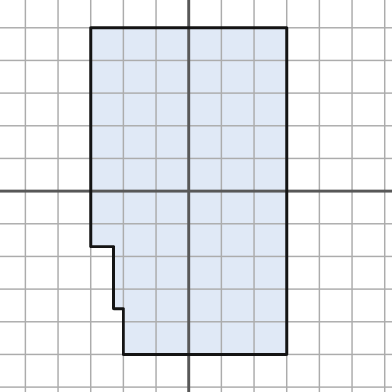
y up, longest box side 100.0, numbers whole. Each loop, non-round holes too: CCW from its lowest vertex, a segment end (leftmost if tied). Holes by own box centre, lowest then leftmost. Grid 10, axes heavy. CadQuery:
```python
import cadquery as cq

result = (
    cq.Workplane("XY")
    .moveTo(-20.0, -50.0)
    .lineTo(30.0, -50.0)
    .lineTo(30.0, 50.0)
    .lineTo(-30.0, 50.0)
    .lineTo(-30.0, -17.0)
    .lineTo(-23.0, -17.0)
    .lineTo(-23.0, -36.0)
    .lineTo(-20.0, -36.0)
    .close()
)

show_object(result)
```